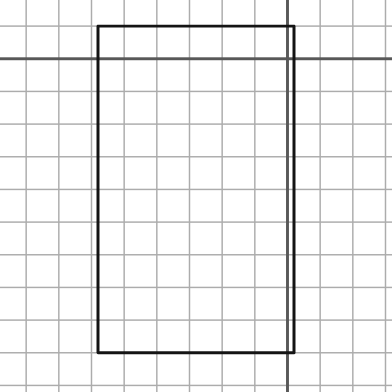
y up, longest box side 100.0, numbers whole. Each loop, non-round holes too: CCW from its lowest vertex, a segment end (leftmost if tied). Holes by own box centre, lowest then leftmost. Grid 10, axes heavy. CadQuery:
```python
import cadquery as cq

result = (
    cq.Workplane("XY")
    .moveTo(-58.0, -90.0)
    .lineTo(2.0, -90.0)
    .lineTo(2.0, 10.0)
    .lineTo(-58.0, 10.0)
    .close()
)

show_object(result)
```